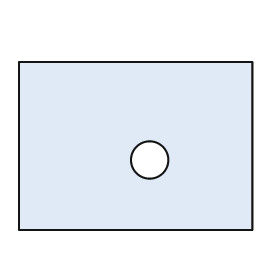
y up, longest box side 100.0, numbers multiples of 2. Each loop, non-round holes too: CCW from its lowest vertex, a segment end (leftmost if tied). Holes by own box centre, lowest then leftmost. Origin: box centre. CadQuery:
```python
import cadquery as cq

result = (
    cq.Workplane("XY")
    .moveTo(-50.0, -36.0)
    .lineTo(50.0, -36.0)
    .lineTo(50.0, 36.0)
    .lineTo(-50.0, 36.0)
    .close()
    .moveTo(6.0, -6.0)
    .circle(8.0)
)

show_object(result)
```